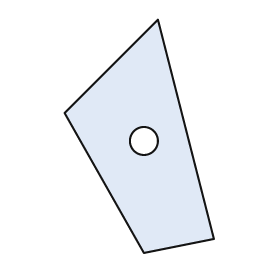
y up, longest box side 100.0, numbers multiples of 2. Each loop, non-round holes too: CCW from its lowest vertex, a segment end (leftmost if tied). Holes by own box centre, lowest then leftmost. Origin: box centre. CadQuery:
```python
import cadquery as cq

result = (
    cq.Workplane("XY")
    .moveTo(2.0, -50.0)
    .lineTo(32.0, -44.0)
    .lineTo(8.0, 50.0)
    .lineTo(-32.0, 10.0)
    .close()
    .moveTo(2.0, -2.0)
    .circle(6.0)
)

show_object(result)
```